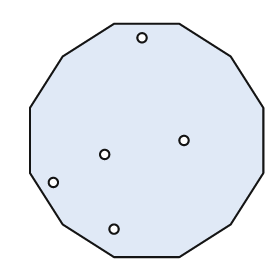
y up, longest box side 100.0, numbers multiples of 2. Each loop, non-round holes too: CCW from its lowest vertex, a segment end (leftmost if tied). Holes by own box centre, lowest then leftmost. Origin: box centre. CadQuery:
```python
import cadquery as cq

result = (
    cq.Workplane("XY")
    .moveTo(-14.0, -50.0)
    .lineTo(14.0, -50.0)
    .lineTo(36.0, -36.0)
    .lineTo(50.0, -14.0)
    .lineTo(50.0, 14.0)
    .lineTo(36.0, 36.0)
    .lineTo(14.0, 50.0)
    .lineTo(-14.0, 50.0)
    .lineTo(-36.0, 36.0)
    .lineTo(-50.0, 14.0)
    .lineTo(-50.0, -14.0)
    .lineTo(-36.0, -36.0)
    .close()
    .moveTo(-14.0, -38.0)
    .circle(2.0)
    .moveTo(-40.0, -18.0)
    .circle(2.0)
    .moveTo(-18.0, -6.0)
    .circle(2.0)
    .moveTo(16.0, 0.0)
    .circle(2.0)
    .moveTo(-2.0, 44.0)
    .circle(2.0)
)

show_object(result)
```